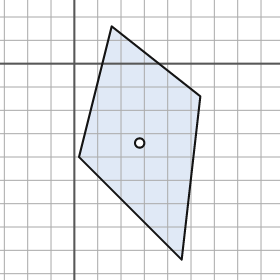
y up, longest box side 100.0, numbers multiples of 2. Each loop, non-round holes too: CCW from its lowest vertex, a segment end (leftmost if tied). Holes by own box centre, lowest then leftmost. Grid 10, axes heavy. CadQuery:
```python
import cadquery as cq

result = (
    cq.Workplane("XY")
    .moveTo(46.0, -84.0)
    .lineTo(54.0, -14.0)
    .lineTo(16.0, 16.0)
    .lineTo(2.0, -40.0)
    .close()
    .moveTo(28.0, -34.0)
    .circle(2.0)
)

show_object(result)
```